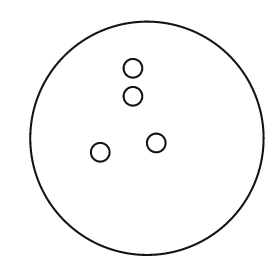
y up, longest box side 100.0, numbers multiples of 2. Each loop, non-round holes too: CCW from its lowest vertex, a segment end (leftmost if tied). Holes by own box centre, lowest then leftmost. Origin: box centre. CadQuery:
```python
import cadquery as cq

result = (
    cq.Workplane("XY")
    .moveTo(0.0, 0.0)
    .circle(50.0)
    .moveTo(-20.0, -6.0)
    .circle(4.0)
    .moveTo(4.0, -2.0)
    .circle(4.0)
    .moveTo(-6.0, 18.0)
    .circle(4.0)
    .moveTo(-6.0, 30.0)
    .circle(4.0)
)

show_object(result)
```